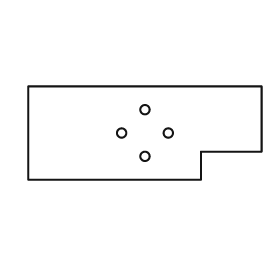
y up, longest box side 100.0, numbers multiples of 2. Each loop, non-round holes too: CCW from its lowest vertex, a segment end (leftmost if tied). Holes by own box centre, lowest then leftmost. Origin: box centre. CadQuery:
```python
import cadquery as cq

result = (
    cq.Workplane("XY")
    .moveTo(-50.0, -20.0)
    .lineTo(24.0, -20.0)
    .lineTo(24.0, -8.0)
    .lineTo(50.0, -8.0)
    .lineTo(50.0, 20.0)
    .lineTo(-50.0, 20.0)
    .close()
    .moveTo(0.0, -10.0)
    .circle(2.0)
    .moveTo(-10.0, 0.0)
    .circle(2.0)
    .moveTo(10.0, 0.0)
    .circle(2.0)
    .moveTo(0.0, 10.0)
    .circle(2.0)
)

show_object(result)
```